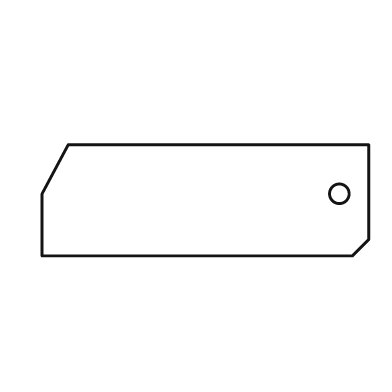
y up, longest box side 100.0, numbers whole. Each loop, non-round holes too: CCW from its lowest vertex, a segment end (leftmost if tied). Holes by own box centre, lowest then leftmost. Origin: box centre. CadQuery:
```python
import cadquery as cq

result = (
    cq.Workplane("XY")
    .moveTo(-50.0, -17.0)
    .lineTo(45.0, -17.0)
    .lineTo(50.0, -12.0)
    .lineTo(50.0, 17.0)
    .lineTo(-42.0, 17.0)
    .lineTo(-50.0, 2.0)
    .close()
    .moveTo(41.0, 2.0)
    .circle(3.0)
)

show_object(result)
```